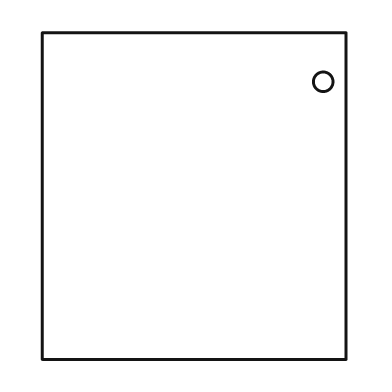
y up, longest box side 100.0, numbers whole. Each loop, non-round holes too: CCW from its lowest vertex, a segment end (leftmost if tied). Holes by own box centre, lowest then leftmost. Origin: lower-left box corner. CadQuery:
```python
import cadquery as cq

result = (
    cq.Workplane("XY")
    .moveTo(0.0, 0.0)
    .lineTo(93.0, 0.0)
    .lineTo(93.0, 100.0)
    .lineTo(0.0, 100.0)
    .close()
    .moveTo(86.0, 85.0)
    .circle(3.0)
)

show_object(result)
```